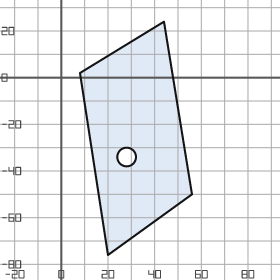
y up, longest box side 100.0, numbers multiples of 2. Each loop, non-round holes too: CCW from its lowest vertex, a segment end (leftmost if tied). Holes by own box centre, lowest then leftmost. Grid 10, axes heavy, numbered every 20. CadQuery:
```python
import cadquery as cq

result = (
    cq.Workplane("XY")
    .moveTo(20.0, -76.0)
    .lineTo(56.0, -50.0)
    .lineTo(44.0, 24.0)
    .lineTo(8.0, 2.0)
    .close()
    .moveTo(28.0, -34.0)
    .circle(4.0)
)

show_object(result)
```